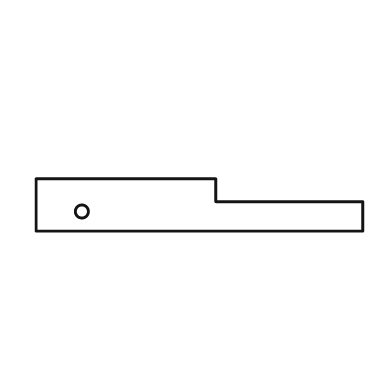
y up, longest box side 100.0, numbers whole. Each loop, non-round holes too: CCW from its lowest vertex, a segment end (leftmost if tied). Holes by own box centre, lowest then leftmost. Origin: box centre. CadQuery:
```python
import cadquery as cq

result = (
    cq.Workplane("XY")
    .moveTo(-50.0, -8.0)
    .lineTo(50.0, -8.0)
    .lineTo(50.0, 1.0)
    .lineTo(5.0, 1.0)
    .lineTo(5.0, 8.0)
    .lineTo(-50.0, 8.0)
    .close()
    .moveTo(-36.0, -2.0)
    .circle(2.0)
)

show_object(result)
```